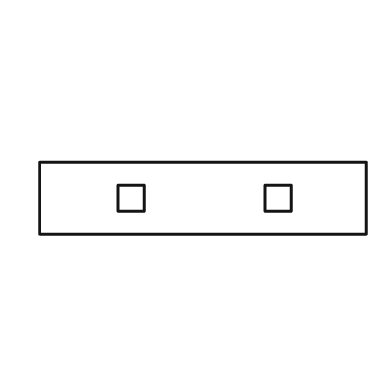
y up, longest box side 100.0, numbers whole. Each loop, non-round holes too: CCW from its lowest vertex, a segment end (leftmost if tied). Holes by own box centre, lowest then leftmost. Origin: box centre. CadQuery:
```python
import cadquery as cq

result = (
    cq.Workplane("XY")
    .moveTo(-50.0, -11.0)
    .lineTo(50.0, -11.0)
    .lineTo(50.0, 11.0)
    .lineTo(-50.0, 11.0)
    .close()
    .moveTo(-26.0, -4.0)
    .lineTo(-18.0, -4.0)
    .lineTo(-18.0, 4.0)
    .lineTo(-26.0, 4.0)
    .close()
    .moveTo(19.0, -4.0)
    .lineTo(27.0, -4.0)
    .lineTo(27.0, 4.0)
    .lineTo(19.0, 4.0)
    .close()
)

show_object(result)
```